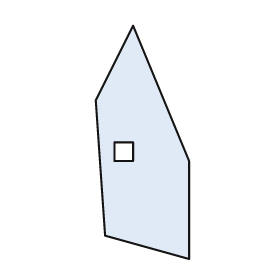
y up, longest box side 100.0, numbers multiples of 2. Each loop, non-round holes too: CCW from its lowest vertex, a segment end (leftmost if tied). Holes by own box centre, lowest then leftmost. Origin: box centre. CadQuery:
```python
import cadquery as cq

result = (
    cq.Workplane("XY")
    .moveTo(20.0, -50.0)
    .lineTo(20.0, -8.0)
    .lineTo(-4.0, 50.0)
    .lineTo(-20.0, 18.0)
    .lineTo(-16.0, -40.0)
    .close()
    .moveTo(-12.0, -8.0)
    .lineTo(-4.0, -8.0)
    .lineTo(-4.0, 0.0)
    .lineTo(-12.0, 0.0)
    .close()
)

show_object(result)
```